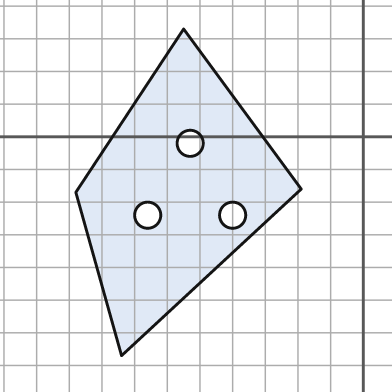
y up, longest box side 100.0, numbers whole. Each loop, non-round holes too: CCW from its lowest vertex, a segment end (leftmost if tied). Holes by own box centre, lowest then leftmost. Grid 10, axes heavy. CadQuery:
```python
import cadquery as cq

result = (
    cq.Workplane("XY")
    .moveTo(-74.0, -67.0)
    .lineTo(-19.0, -16.0)
    .lineTo(-55.0, 33.0)
    .lineTo(-88.0, -17.0)
    .close()
    .moveTo(-66.0, -24.0)
    .circle(4.0)
    .moveTo(-40.0, -24.0)
    .circle(4.0)
    .moveTo(-53.0, -2.0)
    .circle(4.0)
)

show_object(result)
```